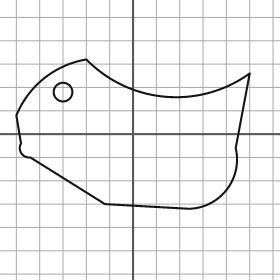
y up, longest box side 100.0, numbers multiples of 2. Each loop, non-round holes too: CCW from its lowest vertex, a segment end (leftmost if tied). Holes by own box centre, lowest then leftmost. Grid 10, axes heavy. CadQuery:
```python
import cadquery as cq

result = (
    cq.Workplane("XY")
    .moveTo(24.0, -32.0)
    .threePointArc((40.0, -24.0), (44.0, -6.0))
    .lineTo(50.0, 26.0)
    .threePointArc((14.0, 16.0), (-20.0, 32.0))
    .threePointArc((-38.0, 24.0), (-50.0, 8.0))
    .lineTo(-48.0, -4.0)
    .threePointArc((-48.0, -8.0), (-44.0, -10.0))
    .lineTo(-12.0, -30.0)
    .close()
    .moveTo(-30.0, 18.0)
    .circle(4.0)
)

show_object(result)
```